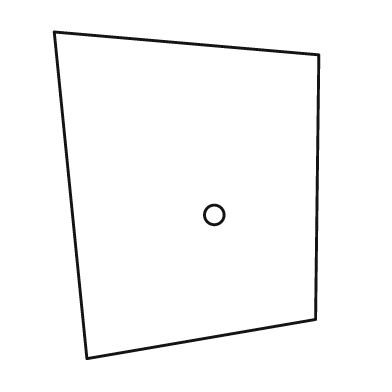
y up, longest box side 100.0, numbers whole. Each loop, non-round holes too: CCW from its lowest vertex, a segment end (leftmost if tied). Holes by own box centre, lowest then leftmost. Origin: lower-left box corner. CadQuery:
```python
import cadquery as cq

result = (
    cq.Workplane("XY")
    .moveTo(10.0, 0.0)
    .lineTo(80.0, 12.0)
    .lineTo(81.0, 93.0)
    .lineTo(0.0, 100.0)
    .close()
    .moveTo(49.0, 44.0)
    .circle(3.0)
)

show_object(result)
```